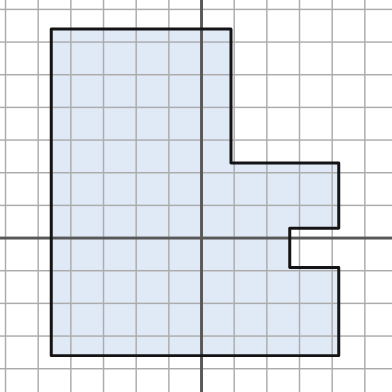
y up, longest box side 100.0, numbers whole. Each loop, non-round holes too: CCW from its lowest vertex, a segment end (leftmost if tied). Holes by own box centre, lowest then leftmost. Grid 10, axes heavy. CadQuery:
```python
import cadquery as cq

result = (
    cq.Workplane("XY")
    .moveTo(-46.0, -36.0)
    .lineTo(42.0, -36.0)
    .lineTo(42.0, -9.0)
    .lineTo(27.0, -9.0)
    .lineTo(27.0, 3.0)
    .lineTo(42.0, 3.0)
    .lineTo(42.0, 23.0)
    .lineTo(9.0, 23.0)
    .lineTo(9.0, 64.0)
    .lineTo(-46.0, 64.0)
    .close()
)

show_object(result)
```